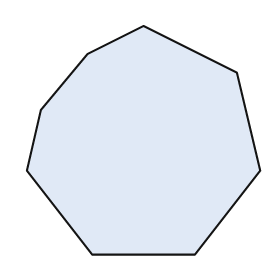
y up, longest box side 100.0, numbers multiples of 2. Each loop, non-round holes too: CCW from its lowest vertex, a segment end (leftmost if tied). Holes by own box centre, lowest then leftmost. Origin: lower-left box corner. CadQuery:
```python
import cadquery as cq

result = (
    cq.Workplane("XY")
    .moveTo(28.0, 0.0)
    .lineTo(72.0, 0.0)
    .lineTo(100.0, 36.0)
    .lineTo(90.0, 78.0)
    .lineTo(50.0, 98.0)
    .lineTo(26.0, 86.0)
    .lineTo(6.0, 62.0)
    .lineTo(0.0, 36.0)
    .close()
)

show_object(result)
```